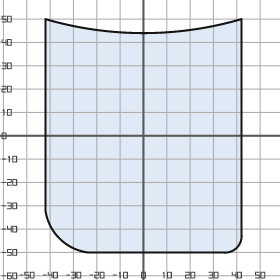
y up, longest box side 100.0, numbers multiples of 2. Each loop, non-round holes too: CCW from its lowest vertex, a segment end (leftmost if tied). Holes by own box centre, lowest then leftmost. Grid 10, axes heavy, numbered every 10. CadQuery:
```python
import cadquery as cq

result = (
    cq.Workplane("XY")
    .moveTo(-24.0, -50.0)
    .lineTo(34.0, -50.0)
    .threePointArc((40.0, -48.0), (42.0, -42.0))
    .lineTo(42.0, 50.0)
    .threePointArc((0.0, 44.0), (-42.0, 50.0))
    .lineTo(-42.0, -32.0)
    .threePointArc((-36.0, -44.0), (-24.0, -50.0))
    .close()
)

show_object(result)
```